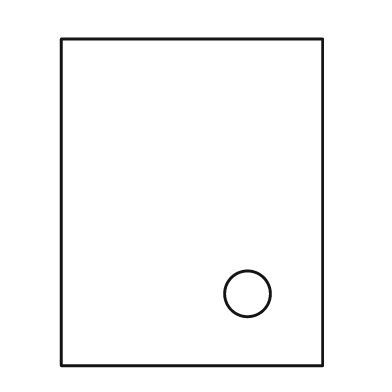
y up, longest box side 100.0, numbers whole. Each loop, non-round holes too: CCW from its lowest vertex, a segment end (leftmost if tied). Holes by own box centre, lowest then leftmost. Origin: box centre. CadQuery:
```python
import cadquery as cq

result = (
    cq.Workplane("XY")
    .moveTo(-40.0, -50.0)
    .lineTo(40.0, -50.0)
    .lineTo(40.0, 50.0)
    .lineTo(-40.0, 50.0)
    .close()
    .moveTo(17.0, -28.0)
    .circle(7.0)
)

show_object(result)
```